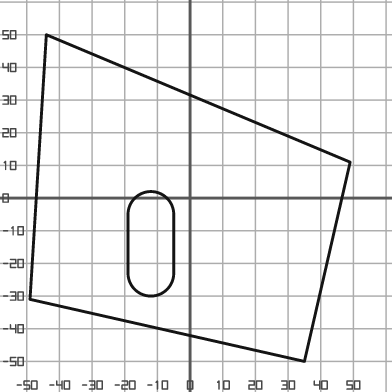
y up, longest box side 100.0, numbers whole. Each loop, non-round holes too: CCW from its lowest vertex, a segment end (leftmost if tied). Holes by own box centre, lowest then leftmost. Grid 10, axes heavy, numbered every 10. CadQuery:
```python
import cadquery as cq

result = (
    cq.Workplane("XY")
    .moveTo(35.0, -50.0)
    .lineTo(49.0, 11.0)
    .lineTo(-44.0, 50.0)
    .lineTo(-49.0, -31.0)
    .close()
    .moveTo(-19.0, -23.0)
    .threePointArc((-12.0, -30.0), (-5.0, -23.0))
    .lineTo(-5.0, -5.0)
    .threePointArc((-12.0, 2.0), (-19.0, -5.0))
    .close()
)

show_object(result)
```